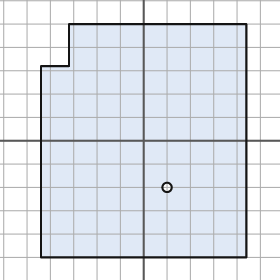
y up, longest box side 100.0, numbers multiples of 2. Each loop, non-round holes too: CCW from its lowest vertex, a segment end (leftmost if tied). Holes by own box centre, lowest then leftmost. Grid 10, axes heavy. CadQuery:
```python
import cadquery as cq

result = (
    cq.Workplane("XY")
    .moveTo(-44.0, -50.0)
    .lineTo(44.0, -50.0)
    .lineTo(44.0, 50.0)
    .lineTo(-32.0, 50.0)
    .lineTo(-32.0, 32.0)
    .lineTo(-44.0, 32.0)
    .close()
    .moveTo(10.0, -20.0)
    .circle(2.0)
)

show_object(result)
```